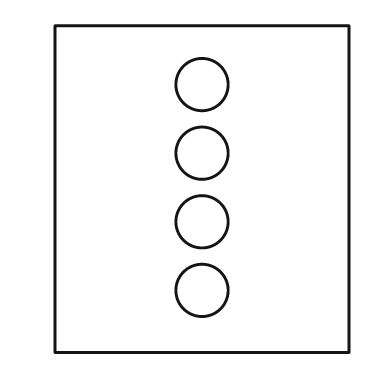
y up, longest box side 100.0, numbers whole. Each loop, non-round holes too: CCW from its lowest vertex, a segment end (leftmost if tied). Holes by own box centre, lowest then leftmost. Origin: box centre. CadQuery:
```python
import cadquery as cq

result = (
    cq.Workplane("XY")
    .moveTo(-45.0, -50.0)
    .lineTo(45.0, -50.0)
    .lineTo(45.0, 50.0)
    .lineTo(-45.0, 50.0)
    .close()
    .moveTo(0.0, -31.0)
    .circle(8.0)
    .moveTo(0.0, -10.0)
    .circle(8.0)
    .moveTo(0.0, 11.0)
    .circle(8.0)
    .moveTo(0.0, 32.0)
    .circle(8.0)
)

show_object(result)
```